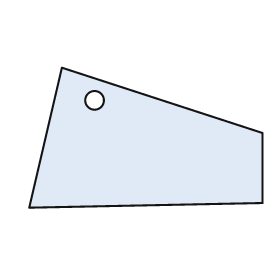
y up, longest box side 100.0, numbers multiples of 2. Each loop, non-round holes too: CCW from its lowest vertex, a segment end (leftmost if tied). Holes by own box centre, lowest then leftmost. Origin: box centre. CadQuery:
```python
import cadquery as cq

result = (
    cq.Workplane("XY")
    .moveTo(-50.0, -30.0)
    .lineTo(50.0, -28.0)
    .lineTo(50.0, 2.0)
    .lineTo(-36.0, 30.0)
    .close()
    .moveTo(-22.0, 16.0)
    .circle(4.0)
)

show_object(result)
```